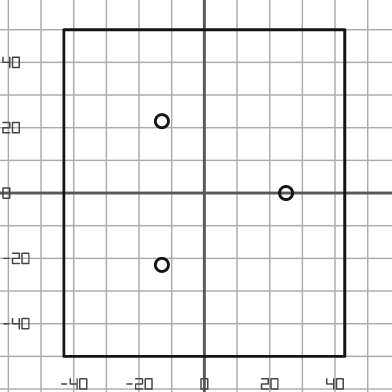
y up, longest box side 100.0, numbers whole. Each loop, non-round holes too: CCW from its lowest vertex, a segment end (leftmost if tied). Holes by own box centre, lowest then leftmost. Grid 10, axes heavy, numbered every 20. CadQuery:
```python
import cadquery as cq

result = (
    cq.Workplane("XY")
    .moveTo(-43.0, -50.0)
    .lineTo(43.0, -50.0)
    .lineTo(43.0, 50.0)
    .lineTo(-43.0, 50.0)
    .close()
    .moveTo(-13.0, -22.0)
    .circle(2.0)
    .moveTo(25.0, 0.0)
    .circle(2.0)
    .moveTo(-13.0, 22.0)
    .circle(2.0)
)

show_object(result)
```